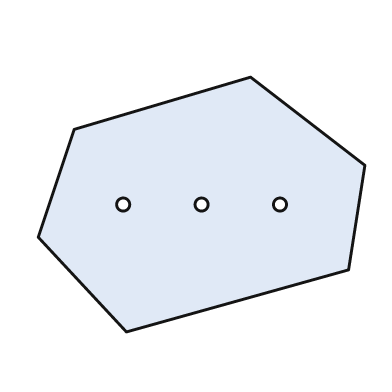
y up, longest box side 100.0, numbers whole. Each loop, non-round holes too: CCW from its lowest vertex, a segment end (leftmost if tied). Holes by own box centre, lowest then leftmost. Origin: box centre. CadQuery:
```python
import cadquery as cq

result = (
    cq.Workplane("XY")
    .moveTo(-23.0, -39.0)
    .lineTo(45.0, -20.0)
    .lineTo(50.0, 12.0)
    .lineTo(15.0, 39.0)
    .lineTo(-39.0, 23.0)
    .lineTo(-50.0, -10.0)
    .close()
    .moveTo(-24.0, 0.0)
    .circle(2.0)
    .moveTo(0.0, 0.0)
    .circle(2.0)
    .moveTo(24.0, 0.0)
    .circle(2.0)
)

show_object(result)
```